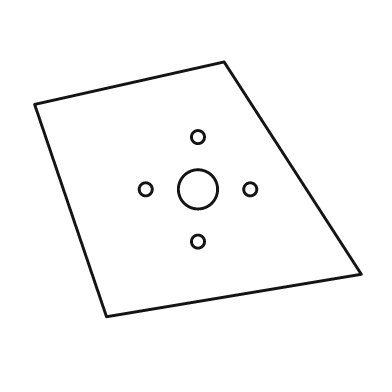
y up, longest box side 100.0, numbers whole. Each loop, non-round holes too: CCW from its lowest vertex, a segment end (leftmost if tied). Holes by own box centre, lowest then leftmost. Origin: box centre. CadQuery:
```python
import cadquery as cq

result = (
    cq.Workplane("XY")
    .moveTo(-28.0, -39.0)
    .lineTo(50.0, -26.0)
    .lineTo(8.0, 39.0)
    .lineTo(-50.0, 26.0)
    .close()
    .moveTo(0.0, -16.0)
    .circle(2.0)
    .moveTo(-16.0, 0.0)
    .circle(2.0)
    .moveTo(0.0, 0.0)
    .circle(6.0)
    .moveTo(16.0, 0.0)
    .circle(2.0)
    .moveTo(0.0, 16.0)
    .circle(2.0)
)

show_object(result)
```